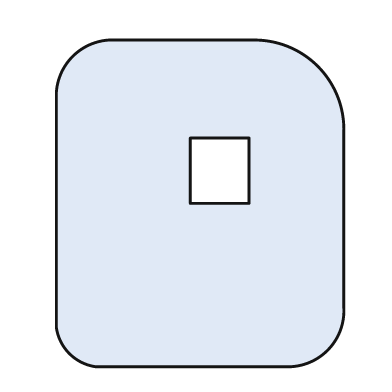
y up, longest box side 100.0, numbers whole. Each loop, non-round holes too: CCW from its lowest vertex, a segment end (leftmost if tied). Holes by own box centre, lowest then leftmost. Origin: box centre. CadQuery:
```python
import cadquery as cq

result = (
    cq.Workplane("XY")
    .moveTo(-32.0, -50.0)
    .lineTo(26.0, -50.0)
    .threePointArc((39.0, -45.0), (44.0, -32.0))
    .lineTo(44.0, 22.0)
    .threePointArc((36.0, 42.0), (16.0, 50.0))
    .lineTo(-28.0, 50.0)
    .threePointArc((-39.0, 45.0), (-44.0, 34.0))
    .lineTo(-44.0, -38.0)
    .threePointArc((-40.0, -46.0), (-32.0, -50.0))
    .close()
    .moveTo(-3.0, 0.0)
    .lineTo(15.0, 0.0)
    .lineTo(15.0, 20.0)
    .lineTo(-3.0, 20.0)
    .close()
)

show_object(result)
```